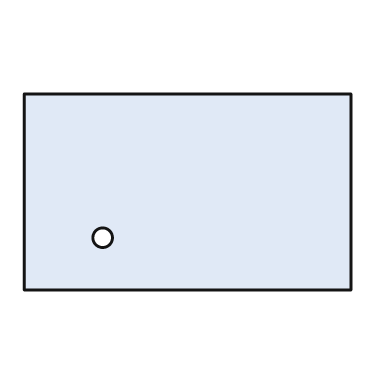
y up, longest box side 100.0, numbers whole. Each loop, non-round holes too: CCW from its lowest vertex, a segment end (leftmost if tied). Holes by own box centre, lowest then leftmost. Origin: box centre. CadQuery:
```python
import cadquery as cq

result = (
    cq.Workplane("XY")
    .moveTo(-50.0, -30.0)
    .lineTo(50.0, -30.0)
    .lineTo(50.0, 30.0)
    .lineTo(-50.0, 30.0)
    .close()
    .moveTo(-26.0, -14.0)
    .circle(3.0)
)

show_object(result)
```